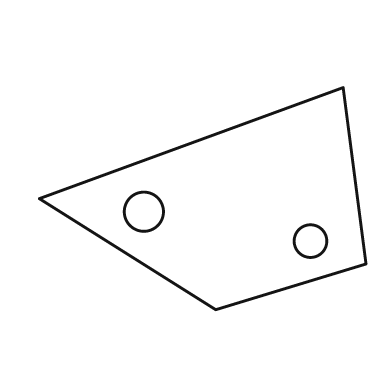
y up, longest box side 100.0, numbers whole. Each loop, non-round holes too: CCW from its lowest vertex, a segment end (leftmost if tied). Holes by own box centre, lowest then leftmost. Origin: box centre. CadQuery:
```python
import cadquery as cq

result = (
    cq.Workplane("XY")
    .moveTo(4.0, -34.0)
    .lineTo(50.0, -20.0)
    .lineTo(43.0, 34.0)
    .lineTo(-50.0, 0.0)
    .close()
    .moveTo(33.0, -13.0)
    .circle(5.0)
    .moveTo(-18.0, -4.0)
    .circle(6.0)
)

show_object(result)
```